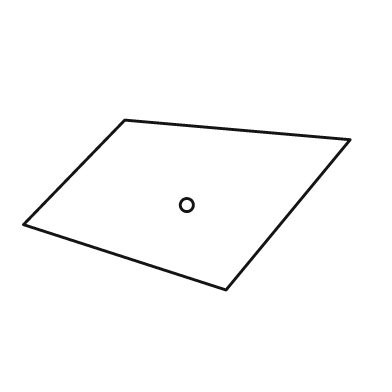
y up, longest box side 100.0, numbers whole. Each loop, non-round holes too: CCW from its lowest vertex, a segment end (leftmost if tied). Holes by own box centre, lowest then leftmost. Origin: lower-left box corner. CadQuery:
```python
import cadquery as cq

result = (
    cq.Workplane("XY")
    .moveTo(62.0, 0.0)
    .lineTo(100.0, 46.0)
    .lineTo(31.0, 52.0)
    .lineTo(0.0, 20.0)
    .close()
    .moveTo(50.0, 26.0)
    .circle(2.0)
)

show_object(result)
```